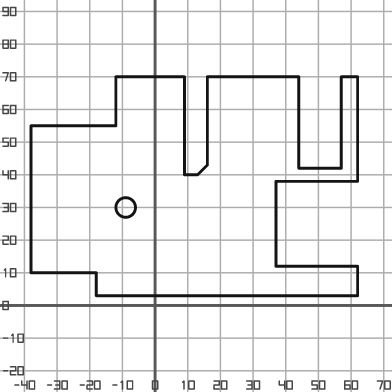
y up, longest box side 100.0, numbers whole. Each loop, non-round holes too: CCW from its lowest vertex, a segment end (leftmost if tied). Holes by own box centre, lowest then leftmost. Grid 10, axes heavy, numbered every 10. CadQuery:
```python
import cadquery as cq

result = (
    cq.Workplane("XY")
    .moveTo(-18.0, 3.0)
    .lineTo(62.0, 3.0)
    .lineTo(62.0, 12.0)
    .lineTo(37.0, 12.0)
    .lineTo(37.0, 38.0)
    .lineTo(62.0, 38.0)
    .lineTo(62.0, 70.0)
    .lineTo(57.0, 70.0)
    .lineTo(57.0, 42.0)
    .lineTo(44.0, 42.0)
    .lineTo(44.0, 70.0)
    .lineTo(16.0, 70.0)
    .lineTo(16.0, 43.0)
    .lineTo(13.0, 40.0)
    .lineTo(9.0, 40.0)
    .lineTo(9.0, 70.0)
    .lineTo(-12.0, 70.0)
    .lineTo(-12.0, 55.0)
    .lineTo(-38.0, 55.0)
    .lineTo(-38.0, 10.0)
    .lineTo(-18.0, 10.0)
    .close()
    .moveTo(-9.0, 30.0)
    .circle(3.0)
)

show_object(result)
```